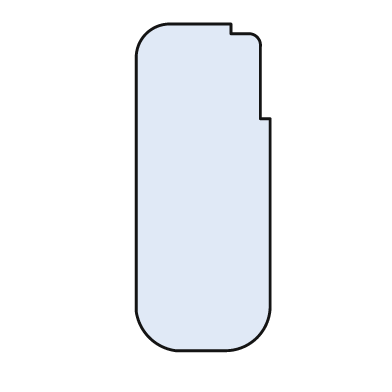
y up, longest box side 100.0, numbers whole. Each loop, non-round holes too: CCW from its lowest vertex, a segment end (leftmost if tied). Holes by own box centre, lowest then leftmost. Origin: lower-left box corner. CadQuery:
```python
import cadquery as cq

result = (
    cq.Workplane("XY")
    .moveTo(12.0, 0.0)
    .lineTo(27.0, 0.0)
    .threePointArc((37.0, 4.0), (41.0, 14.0))
    .lineTo(41.0, 71.0)
    .lineTo(38.0, 71.0)
    .lineTo(38.0, 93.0)
    .threePointArc((37.0, 96.0), (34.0, 97.0))
    .lineTo(29.0, 97.0)
    .lineTo(29.0, 100.0)
    .lineTo(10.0, 100.0)
    .threePointArc((3.0, 97.0), (0.0, 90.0))
    .lineTo(0.0, 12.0)
    .threePointArc((4.0, 4.0), (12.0, 0.0))
    .close()
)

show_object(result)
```